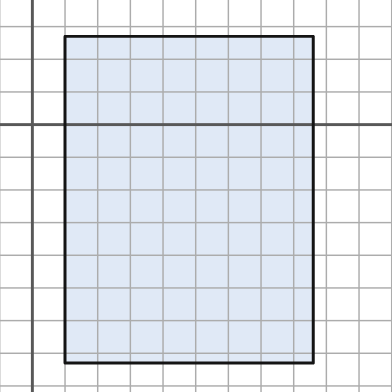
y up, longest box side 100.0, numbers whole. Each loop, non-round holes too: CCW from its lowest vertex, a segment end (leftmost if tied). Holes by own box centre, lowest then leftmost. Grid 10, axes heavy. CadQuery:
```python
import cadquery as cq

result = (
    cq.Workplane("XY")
    .moveTo(10.0, -73.0)
    .lineTo(86.0, -73.0)
    .lineTo(86.0, 27.0)
    .lineTo(10.0, 27.0)
    .close()
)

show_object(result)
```